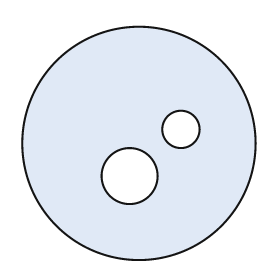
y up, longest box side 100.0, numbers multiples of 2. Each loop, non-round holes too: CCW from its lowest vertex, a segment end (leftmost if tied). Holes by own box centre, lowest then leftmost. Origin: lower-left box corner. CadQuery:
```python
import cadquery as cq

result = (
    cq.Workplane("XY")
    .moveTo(50.0, 50.0)
    .circle(50.0)
    .moveTo(46.0, 36.0)
    .circle(12.0)
    .moveTo(68.0, 56.0)
    .circle(8.0)
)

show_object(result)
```